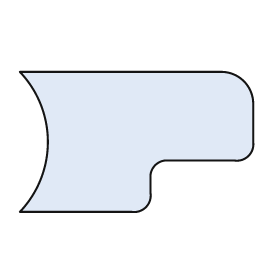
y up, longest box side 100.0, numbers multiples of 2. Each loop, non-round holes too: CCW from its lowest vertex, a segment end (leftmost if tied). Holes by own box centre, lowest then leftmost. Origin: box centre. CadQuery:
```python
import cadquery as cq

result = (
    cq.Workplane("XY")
    .moveTo(-50.0, -30.0)
    .lineTo(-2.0, -30.0)
    .threePointArc((4.0, -28.0), (6.0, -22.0))
    .lineTo(6.0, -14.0)
    .threePointArc((8.0, -10.0), (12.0, -8.0))
    .lineTo(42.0, -8.0)
    .threePointArc((48.0, -6.0), (50.0, 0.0))
    .lineTo(50.0, 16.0)
    .threePointArc((46.0, 26.0), (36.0, 30.0))
    .lineTo(-50.0, 30.0)
    .threePointArc((-38.0, 0.0), (-50.0, -30.0))
    .close()
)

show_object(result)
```